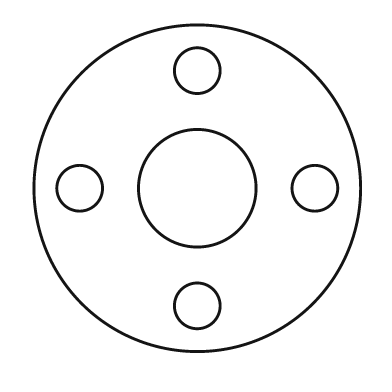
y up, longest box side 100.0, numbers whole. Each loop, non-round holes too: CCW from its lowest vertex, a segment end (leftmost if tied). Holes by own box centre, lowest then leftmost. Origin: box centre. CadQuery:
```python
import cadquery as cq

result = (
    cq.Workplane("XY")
    .moveTo(0.0, 0.0)
    .circle(50.0)
    .moveTo(0.0, -36.0)
    .circle(7.0)
    .moveTo(-36.0, 0.0)
    .circle(7.0)
    .moveTo(0.0, 0.0)
    .circle(18.0)
    .moveTo(36.0, 0.0)
    .circle(7.0)
    .moveTo(0.0, 36.0)
    .circle(7.0)
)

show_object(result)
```